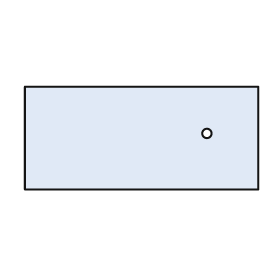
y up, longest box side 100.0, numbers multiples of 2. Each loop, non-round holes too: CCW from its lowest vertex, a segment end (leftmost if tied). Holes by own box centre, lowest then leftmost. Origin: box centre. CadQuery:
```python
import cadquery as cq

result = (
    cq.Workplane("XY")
    .moveTo(-50.0, -22.0)
    .lineTo(50.0, -22.0)
    .lineTo(50.0, 22.0)
    .lineTo(-50.0, 22.0)
    .close()
    .moveTo(28.0, 2.0)
    .circle(2.0)
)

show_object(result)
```